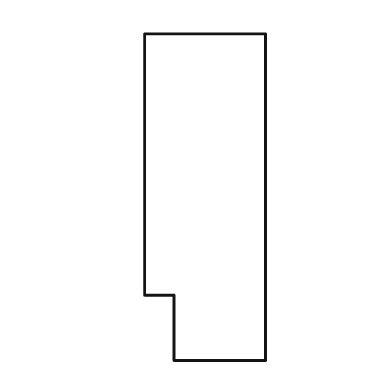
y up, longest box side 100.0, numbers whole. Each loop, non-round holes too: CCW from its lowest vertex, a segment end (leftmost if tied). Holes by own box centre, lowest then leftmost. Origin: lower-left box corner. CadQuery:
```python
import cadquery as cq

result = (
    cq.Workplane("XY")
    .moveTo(9.0, 0.0)
    .lineTo(37.0, 0.0)
    .lineTo(37.0, 100.0)
    .lineTo(0.0, 100.0)
    .lineTo(0.0, 20.0)
    .lineTo(9.0, 20.0)
    .close()
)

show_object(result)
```